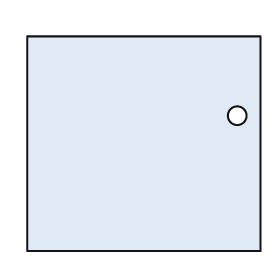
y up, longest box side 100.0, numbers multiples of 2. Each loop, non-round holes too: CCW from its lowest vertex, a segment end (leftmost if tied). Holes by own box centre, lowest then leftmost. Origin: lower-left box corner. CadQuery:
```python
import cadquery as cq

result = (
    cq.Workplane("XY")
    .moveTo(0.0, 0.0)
    .lineTo(100.0, 0.0)
    .lineTo(100.0, 92.0)
    .lineTo(0.0, 92.0)
    .close()
    .moveTo(90.0, 58.0)
    .circle(4.0)
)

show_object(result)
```